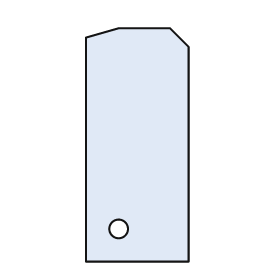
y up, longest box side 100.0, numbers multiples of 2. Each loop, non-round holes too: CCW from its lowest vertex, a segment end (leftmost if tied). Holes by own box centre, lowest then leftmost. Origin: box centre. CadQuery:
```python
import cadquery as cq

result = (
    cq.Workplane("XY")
    .moveTo(-22.0, -50.0)
    .lineTo(22.0, -50.0)
    .lineTo(22.0, 42.0)
    .lineTo(14.0, 50.0)
    .lineTo(-8.0, 50.0)
    .lineTo(-22.0, 46.0)
    .close()
    .moveTo(-8.0, -36.0)
    .circle(4.0)
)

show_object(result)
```